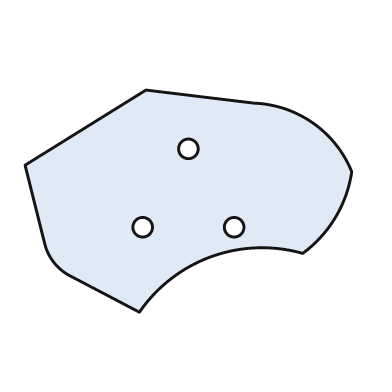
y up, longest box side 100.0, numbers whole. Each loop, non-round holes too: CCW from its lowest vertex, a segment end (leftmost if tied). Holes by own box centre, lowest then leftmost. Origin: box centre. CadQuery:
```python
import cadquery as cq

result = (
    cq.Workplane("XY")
    .moveTo(-15.0, -34.0)
    .threePointArc((7.0, -17.0), (35.0, -16.0))
    .threePointArc((45.0, -5.0), (50.0, 9.0))
    .threePointArc((38.0, 24.0), (20.0, 30.0))
    .lineTo(-13.0, 34.0)
    .lineTo(-50.0, 11.0)
    .lineTo(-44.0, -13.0)
    .threePointArc((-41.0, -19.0), (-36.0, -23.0))
    .close()
    .moveTo(-14.0, -8.0)
    .circle(3.0)
    .moveTo(14.0, -8.0)
    .circle(3.0)
    .moveTo(0.0, 16.0)
    .circle(3.0)
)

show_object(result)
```